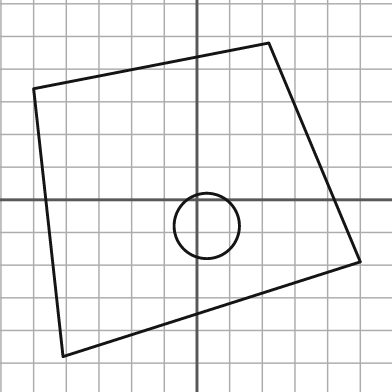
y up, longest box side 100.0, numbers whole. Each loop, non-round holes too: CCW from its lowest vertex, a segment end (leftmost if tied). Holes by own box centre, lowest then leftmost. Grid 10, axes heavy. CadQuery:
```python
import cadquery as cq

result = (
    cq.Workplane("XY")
    .moveTo(-41.0, -48.0)
    .lineTo(50.0, -19.0)
    .lineTo(22.0, 48.0)
    .lineTo(-50.0, 34.0)
    .close()
    .moveTo(3.0, -8.0)
    .circle(10.0)
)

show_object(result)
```